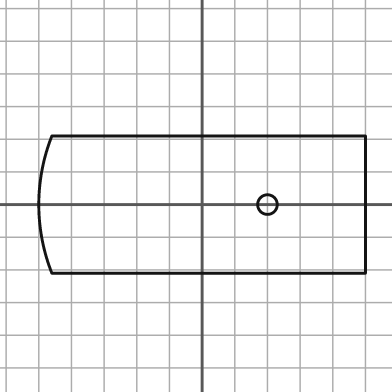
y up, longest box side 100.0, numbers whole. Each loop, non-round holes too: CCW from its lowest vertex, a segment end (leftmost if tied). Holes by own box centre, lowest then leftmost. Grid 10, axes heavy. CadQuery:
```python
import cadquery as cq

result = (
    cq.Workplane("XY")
    .moveTo(-46.0, -21.0)
    .lineTo(50.0, -21.0)
    .lineTo(50.0, 21.0)
    .lineTo(-46.0, 21.0)
    .threePointArc((-50.0, 0.0), (-46.0, -21.0))
    .close()
    .moveTo(20.0, 0.0)
    .circle(3.0)
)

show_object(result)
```